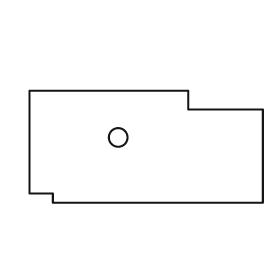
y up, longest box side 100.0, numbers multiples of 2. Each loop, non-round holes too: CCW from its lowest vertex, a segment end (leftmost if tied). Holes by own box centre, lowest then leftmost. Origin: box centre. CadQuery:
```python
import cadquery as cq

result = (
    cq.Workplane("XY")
    .moveTo(-40.0, -24.0)
    .lineTo(50.0, -24.0)
    .lineTo(50.0, 16.0)
    .lineTo(18.0, 16.0)
    .lineTo(18.0, 24.0)
    .lineTo(-50.0, 24.0)
    .lineTo(-50.0, -20.0)
    .lineTo(-40.0, -20.0)
    .close()
    .moveTo(-12.0, 4.0)
    .circle(4.0)
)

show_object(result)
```